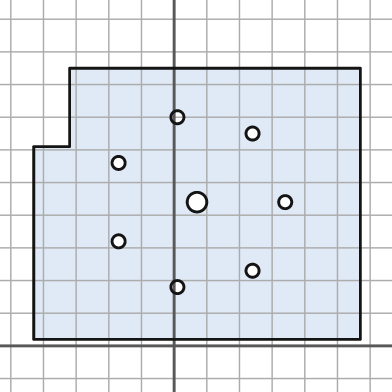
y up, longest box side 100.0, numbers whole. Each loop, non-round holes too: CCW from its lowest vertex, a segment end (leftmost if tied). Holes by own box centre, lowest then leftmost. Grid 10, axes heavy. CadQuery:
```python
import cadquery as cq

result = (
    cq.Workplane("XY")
    .moveTo(-43.0, 2.0)
    .lineTo(57.0, 2.0)
    .lineTo(57.0, 85.0)
    .lineTo(-32.0, 85.0)
    .lineTo(-32.0, 61.0)
    .lineTo(-43.0, 61.0)
    .close()
    .moveTo(1.0, 18.0)
    .circle(2.0)
    .moveTo(24.0, 23.0)
    .circle(2.0)
    .moveTo(-17.0, 32.0)
    .circle(2.0)
    .moveTo(7.0, 44.0)
    .circle(3.0)
    .moveTo(34.0, 44.0)
    .circle(2.0)
    .moveTo(-17.0, 56.0)
    .circle(2.0)
    .moveTo(24.0, 65.0)
    .circle(2.0)
    .moveTo(1.0, 70.0)
    .circle(2.0)
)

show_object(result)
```